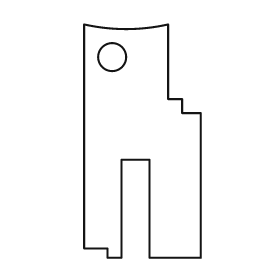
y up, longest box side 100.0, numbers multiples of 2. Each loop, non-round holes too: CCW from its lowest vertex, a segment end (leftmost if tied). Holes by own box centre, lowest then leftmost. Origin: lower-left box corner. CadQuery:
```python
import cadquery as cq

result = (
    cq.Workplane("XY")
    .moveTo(10.0, 0.0)
    .lineTo(16.0, 0.0)
    .lineTo(16.0, 42.0)
    .lineTo(28.0, 42.0)
    .lineTo(28.0, 0.0)
    .lineTo(50.0, 0.0)
    .lineTo(50.0, 62.0)
    .lineTo(42.0, 62.0)
    .lineTo(42.0, 68.0)
    .lineTo(36.0, 68.0)
    .lineTo(36.0, 100.0)
    .threePointArc((18.0, 98.0), (0.0, 100.0))
    .lineTo(0.0, 4.0)
    .lineTo(10.0, 4.0)
    .close()
    .moveTo(12.0, 86.0)
    .circle(6.0)
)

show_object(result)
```